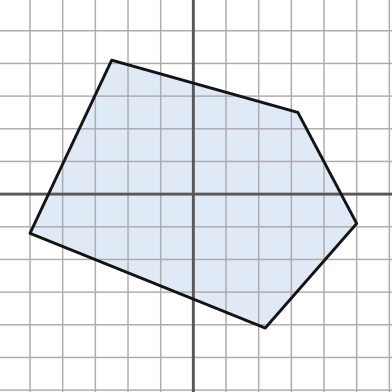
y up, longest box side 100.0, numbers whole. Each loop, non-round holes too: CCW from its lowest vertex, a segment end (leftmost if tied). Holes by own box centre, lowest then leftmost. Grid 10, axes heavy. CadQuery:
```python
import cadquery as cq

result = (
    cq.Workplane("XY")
    .moveTo(22.0, -41.0)
    .lineTo(50.0, -9.0)
    .lineTo(32.0, 25.0)
    .lineTo(-25.0, 41.0)
    .lineTo(-50.0, -12.0)
    .close()
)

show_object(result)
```